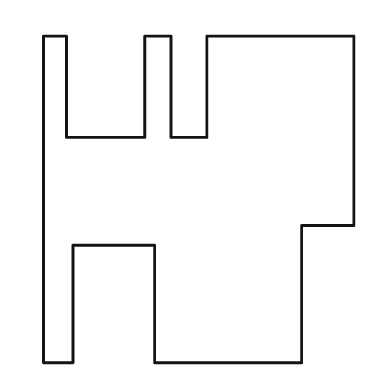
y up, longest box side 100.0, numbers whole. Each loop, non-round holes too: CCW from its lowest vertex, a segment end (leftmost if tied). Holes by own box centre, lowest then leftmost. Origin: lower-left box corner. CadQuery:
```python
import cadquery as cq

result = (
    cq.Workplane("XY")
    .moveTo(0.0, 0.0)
    .lineTo(9.0, 0.0)
    .lineTo(9.0, 36.0)
    .lineTo(34.0, 36.0)
    .lineTo(34.0, 0.0)
    .lineTo(79.0, 0.0)
    .lineTo(79.0, 42.0)
    .lineTo(95.0, 42.0)
    .lineTo(95.0, 100.0)
    .lineTo(50.0, 100.0)
    .lineTo(50.0, 69.0)
    .lineTo(39.0, 69.0)
    .lineTo(39.0, 100.0)
    .lineTo(31.0, 100.0)
    .lineTo(31.0, 69.0)
    .lineTo(7.0, 69.0)
    .lineTo(7.0, 100.0)
    .lineTo(0.0, 100.0)
    .close()
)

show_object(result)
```